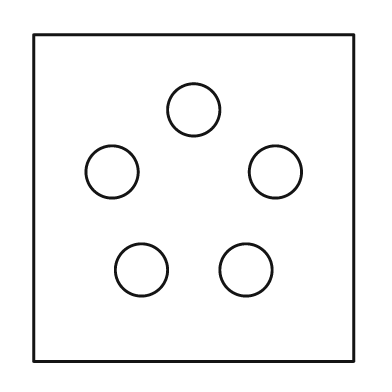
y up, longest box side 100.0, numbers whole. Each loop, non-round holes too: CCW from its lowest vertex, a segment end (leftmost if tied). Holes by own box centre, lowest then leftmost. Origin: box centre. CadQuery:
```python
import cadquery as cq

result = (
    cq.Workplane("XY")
    .moveTo(-49.0, -50.0)
    .lineTo(49.0, -50.0)
    .lineTo(49.0, 50.0)
    .lineTo(-49.0, 50.0)
    .close()
    .moveTo(-16.0, -22.0)
    .circle(8.0)
    .moveTo(16.0, -22.0)
    .circle(8.0)
    .moveTo(-25.0, 8.0)
    .circle(8.0)
    .moveTo(25.0, 8.0)
    .circle(8.0)
    .moveTo(0.0, 27.0)
    .circle(8.0)
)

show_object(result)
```